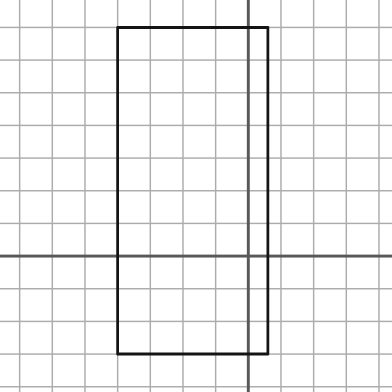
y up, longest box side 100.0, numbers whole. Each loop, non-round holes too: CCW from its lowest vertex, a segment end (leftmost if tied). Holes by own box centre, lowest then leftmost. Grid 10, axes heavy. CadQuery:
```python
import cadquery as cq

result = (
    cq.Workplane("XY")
    .moveTo(-40.0, -30.0)
    .lineTo(6.0, -30.0)
    .lineTo(6.0, 70.0)
    .lineTo(-40.0, 70.0)
    .close()
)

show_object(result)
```